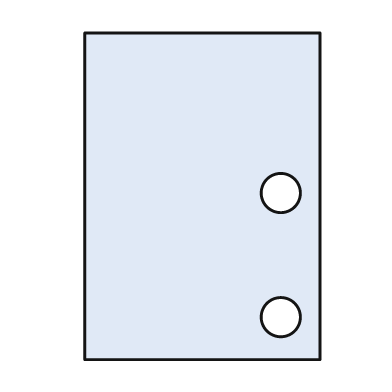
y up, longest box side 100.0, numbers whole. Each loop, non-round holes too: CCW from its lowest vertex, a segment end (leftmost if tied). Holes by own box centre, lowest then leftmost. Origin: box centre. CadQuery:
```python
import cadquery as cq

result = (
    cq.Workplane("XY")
    .moveTo(-36.0, -50.0)
    .lineTo(36.0, -50.0)
    .lineTo(36.0, 50.0)
    .lineTo(-36.0, 50.0)
    .close()
    .moveTo(24.0, -37.0)
    .circle(6.0)
    .moveTo(24.0, 1.0)
    .circle(6.0)
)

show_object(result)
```